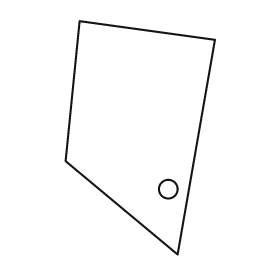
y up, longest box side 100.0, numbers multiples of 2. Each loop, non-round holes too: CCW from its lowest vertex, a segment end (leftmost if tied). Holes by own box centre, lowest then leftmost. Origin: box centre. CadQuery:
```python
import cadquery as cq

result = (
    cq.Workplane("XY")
    .moveTo(16.0, -50.0)
    .lineTo(32.0, 42.0)
    .lineTo(-26.0, 50.0)
    .lineTo(-32.0, -10.0)
    .close()
    .moveTo(12.0, -22.0)
    .circle(4.0)
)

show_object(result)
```